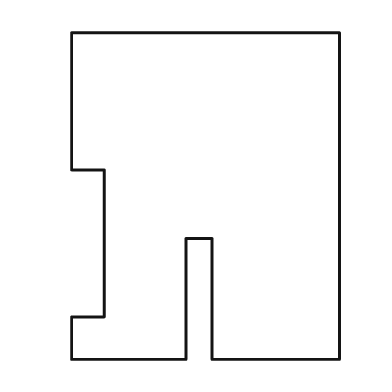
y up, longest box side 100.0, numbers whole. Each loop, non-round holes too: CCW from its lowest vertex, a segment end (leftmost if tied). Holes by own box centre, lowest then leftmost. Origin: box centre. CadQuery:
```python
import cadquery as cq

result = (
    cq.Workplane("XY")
    .moveTo(-41.0, -50.0)
    .lineTo(-6.0, -50.0)
    .lineTo(-6.0, -13.0)
    .lineTo(2.0, -13.0)
    .lineTo(2.0, -50.0)
    .lineTo(41.0, -50.0)
    .lineTo(41.0, 50.0)
    .lineTo(-41.0, 50.0)
    .lineTo(-41.0, 8.0)
    .lineTo(-31.0, 8.0)
    .lineTo(-31.0, -37.0)
    .lineTo(-41.0, -37.0)
    .close()
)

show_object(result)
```